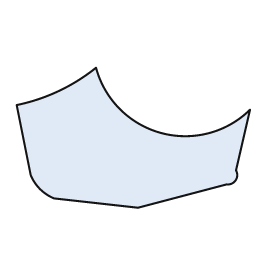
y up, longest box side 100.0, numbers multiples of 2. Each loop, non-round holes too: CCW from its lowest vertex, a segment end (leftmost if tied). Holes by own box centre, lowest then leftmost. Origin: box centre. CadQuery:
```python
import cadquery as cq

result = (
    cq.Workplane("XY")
    .moveTo(2.0, -30.0)
    .lineTo(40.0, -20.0)
    .threePointArc((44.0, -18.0), (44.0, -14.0))
    .lineTo(50.0, 12.0)
    .threePointArc((12.0, 2.0), (-16.0, 30.0))
    .threePointArc((-32.0, 20.0), (-50.0, 14.0))
    .lineTo(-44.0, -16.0)
    .threePointArc((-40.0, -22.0), (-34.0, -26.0))
    .close()
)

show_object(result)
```